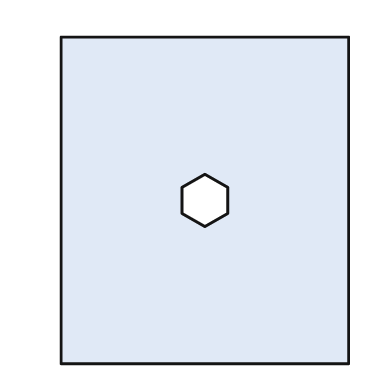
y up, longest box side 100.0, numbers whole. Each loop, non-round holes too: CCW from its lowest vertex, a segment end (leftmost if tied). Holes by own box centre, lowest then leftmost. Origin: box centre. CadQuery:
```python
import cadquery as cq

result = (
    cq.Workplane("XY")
    .moveTo(-44.0, -50.0)
    .lineTo(44.0, -50.0)
    .lineTo(44.0, 50.0)
    .lineTo(-44.0, 50.0)
    .close()
    .moveTo(0.0, -8.0)
    .lineTo(7.0, -4.0)
    .lineTo(7.0, 4.0)
    .lineTo(0.0, 8.0)
    .lineTo(-7.0, 4.0)
    .lineTo(-7.0, -4.0)
    .close()
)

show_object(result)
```